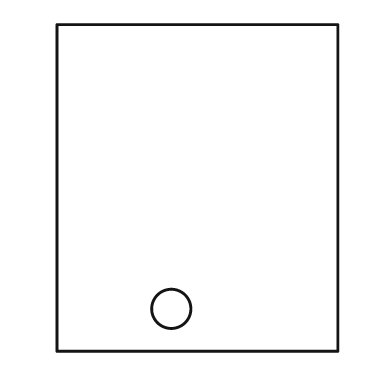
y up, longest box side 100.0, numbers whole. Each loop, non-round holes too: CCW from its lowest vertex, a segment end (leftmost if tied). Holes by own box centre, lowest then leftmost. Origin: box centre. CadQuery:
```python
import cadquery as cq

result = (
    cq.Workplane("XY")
    .moveTo(-43.0, -50.0)
    .lineTo(43.0, -50.0)
    .lineTo(43.0, 50.0)
    .lineTo(-43.0, 50.0)
    .close()
    .moveTo(-8.0, -37.0)
    .circle(6.0)
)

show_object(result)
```